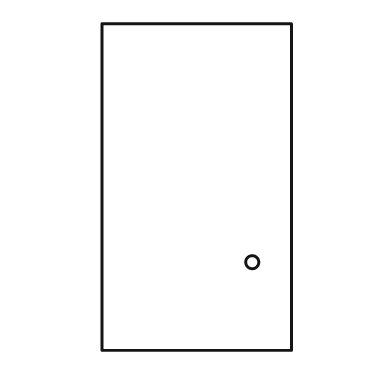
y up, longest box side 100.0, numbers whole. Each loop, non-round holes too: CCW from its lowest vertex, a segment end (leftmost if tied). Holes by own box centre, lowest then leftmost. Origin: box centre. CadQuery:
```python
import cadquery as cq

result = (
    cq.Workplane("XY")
    .moveTo(-29.0, -50.0)
    .lineTo(29.0, -50.0)
    .lineTo(29.0, 50.0)
    .lineTo(-29.0, 50.0)
    .close()
    .moveTo(17.0, -23.0)
    .circle(2.0)
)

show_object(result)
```